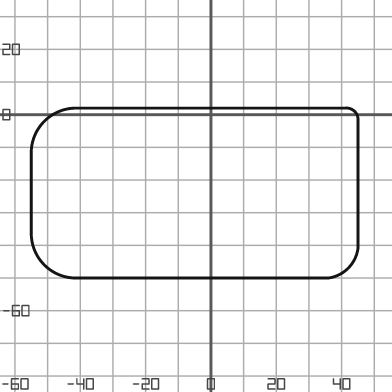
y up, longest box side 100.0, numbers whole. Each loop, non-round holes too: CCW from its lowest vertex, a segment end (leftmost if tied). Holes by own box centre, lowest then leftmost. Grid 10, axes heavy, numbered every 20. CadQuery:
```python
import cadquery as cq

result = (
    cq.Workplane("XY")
    .moveTo(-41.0, -50.0)
    .lineTo(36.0, -50.0)
    .threePointArc((42.0, -47.0), (45.0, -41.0))
    .lineTo(45.0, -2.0)
    .threePointArc((44.0, 1.0), (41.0, 2.0))
    .lineTo(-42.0, 2.0)
    .threePointArc((-51.0, -2.0), (-55.0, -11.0))
    .lineTo(-55.0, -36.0)
    .threePointArc((-51.0, -46.0), (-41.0, -50.0))
    .close()
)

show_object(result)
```